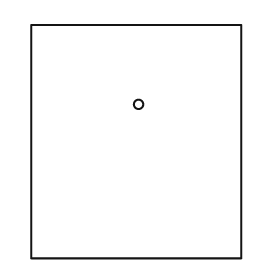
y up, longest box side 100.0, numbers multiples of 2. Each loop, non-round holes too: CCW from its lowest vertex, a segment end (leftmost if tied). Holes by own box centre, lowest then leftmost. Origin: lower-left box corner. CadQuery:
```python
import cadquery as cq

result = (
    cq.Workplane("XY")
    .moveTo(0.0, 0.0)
    .lineTo(90.0, 0.0)
    .lineTo(90.0, 100.0)
    .lineTo(0.0, 100.0)
    .close()
    .moveTo(46.0, 66.0)
    .circle(2.0)
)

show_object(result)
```